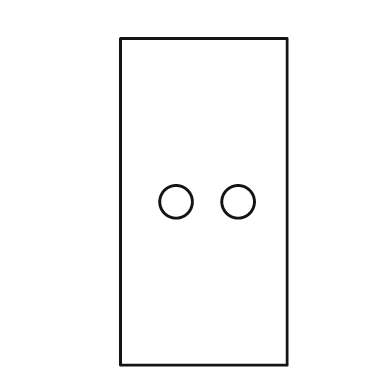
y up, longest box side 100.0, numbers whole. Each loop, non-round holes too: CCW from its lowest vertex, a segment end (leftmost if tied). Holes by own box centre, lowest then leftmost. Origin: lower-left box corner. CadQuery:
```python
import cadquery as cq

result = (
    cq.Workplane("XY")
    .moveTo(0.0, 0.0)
    .lineTo(51.0, 0.0)
    .lineTo(51.0, 100.0)
    .lineTo(0.0, 100.0)
    .close()
    .moveTo(17.0, 50.0)
    .circle(5.0)
    .moveTo(36.0, 50.0)
    .circle(5.0)
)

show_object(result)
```